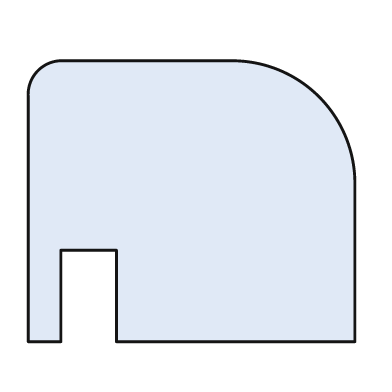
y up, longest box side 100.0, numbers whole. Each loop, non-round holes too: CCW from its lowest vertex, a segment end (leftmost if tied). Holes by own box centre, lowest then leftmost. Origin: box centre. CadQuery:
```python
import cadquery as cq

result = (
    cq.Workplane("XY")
    .moveTo(-50.0, -43.0)
    .lineTo(-40.0, -43.0)
    .lineTo(-40.0, -15.0)
    .lineTo(-23.0, -15.0)
    .lineTo(-23.0, -43.0)
    .lineTo(50.0, -43.0)
    .lineTo(50.0, 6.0)
    .threePointArc((39.0, 32.0), (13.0, 43.0))
    .lineTo(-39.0, 43.0)
    .threePointArc((-47.0, 40.0), (-50.0, 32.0))
    .close()
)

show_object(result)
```